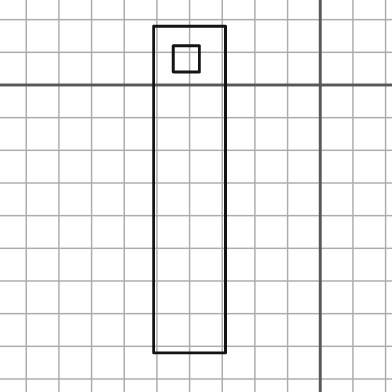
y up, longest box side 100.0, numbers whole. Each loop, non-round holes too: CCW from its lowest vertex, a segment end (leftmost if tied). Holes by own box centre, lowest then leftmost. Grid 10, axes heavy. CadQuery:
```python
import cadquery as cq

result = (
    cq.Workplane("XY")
    .moveTo(-51.0, -82.0)
    .lineTo(-29.0, -82.0)
    .lineTo(-29.0, 18.0)
    .lineTo(-51.0, 18.0)
    .close()
    .moveTo(-45.0, 4.0)
    .lineTo(-37.0, 4.0)
    .lineTo(-37.0, 12.0)
    .lineTo(-45.0, 12.0)
    .close()
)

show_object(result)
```